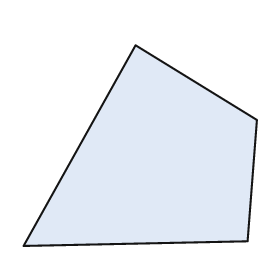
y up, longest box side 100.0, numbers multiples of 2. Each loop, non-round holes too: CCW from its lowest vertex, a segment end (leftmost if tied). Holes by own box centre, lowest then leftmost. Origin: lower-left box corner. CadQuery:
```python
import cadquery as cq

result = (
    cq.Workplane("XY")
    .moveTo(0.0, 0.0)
    .lineTo(96.0, 2.0)
    .lineTo(100.0, 54.0)
    .lineTo(48.0, 86.0)
    .close()
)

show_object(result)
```